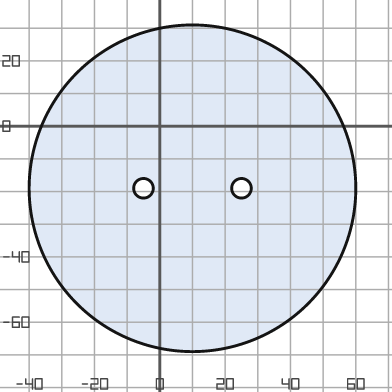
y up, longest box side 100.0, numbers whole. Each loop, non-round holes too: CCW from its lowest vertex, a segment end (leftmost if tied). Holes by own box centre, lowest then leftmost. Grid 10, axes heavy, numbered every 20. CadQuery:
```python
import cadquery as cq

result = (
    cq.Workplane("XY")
    .moveTo(10.0, -19.0)
    .circle(50.0)
    .moveTo(-5.0, -19.0)
    .circle(3.0)
    .moveTo(25.0, -19.0)
    .circle(3.0)
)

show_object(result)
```